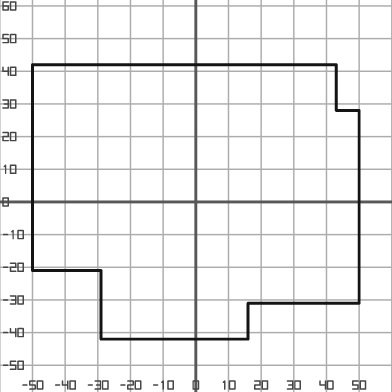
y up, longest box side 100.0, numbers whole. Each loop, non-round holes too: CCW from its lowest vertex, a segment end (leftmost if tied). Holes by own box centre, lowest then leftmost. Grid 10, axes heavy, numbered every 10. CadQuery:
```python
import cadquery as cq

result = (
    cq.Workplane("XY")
    .moveTo(-29.0, -42.0)
    .lineTo(16.0, -42.0)
    .lineTo(16.0, -31.0)
    .lineTo(50.0, -31.0)
    .lineTo(50.0, 28.0)
    .lineTo(43.0, 28.0)
    .lineTo(43.0, 42.0)
    .lineTo(-50.0, 42.0)
    .lineTo(-50.0, -21.0)
    .lineTo(-29.0, -21.0)
    .close()
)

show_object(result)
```